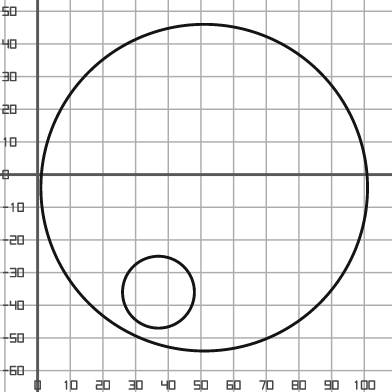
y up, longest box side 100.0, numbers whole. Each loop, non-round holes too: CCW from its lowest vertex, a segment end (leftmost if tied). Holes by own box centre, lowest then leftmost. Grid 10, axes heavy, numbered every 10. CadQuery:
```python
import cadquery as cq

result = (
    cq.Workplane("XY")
    .moveTo(51.0, -4.0)
    .circle(50.0)
    .moveTo(37.0, -36.0)
    .circle(11.0)
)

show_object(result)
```